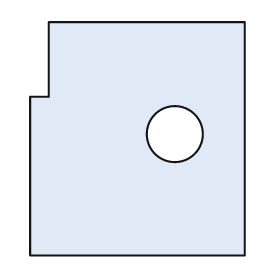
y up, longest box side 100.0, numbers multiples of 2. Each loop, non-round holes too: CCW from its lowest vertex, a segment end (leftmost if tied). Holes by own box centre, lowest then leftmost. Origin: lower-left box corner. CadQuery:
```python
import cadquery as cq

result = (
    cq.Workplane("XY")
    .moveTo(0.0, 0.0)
    .lineTo(92.0, 0.0)
    .lineTo(92.0, 100.0)
    .lineTo(8.0, 100.0)
    .lineTo(8.0, 68.0)
    .lineTo(0.0, 68.0)
    .close()
    .moveTo(62.0, 52.0)
    .circle(12.0)
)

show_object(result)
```